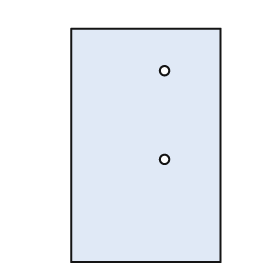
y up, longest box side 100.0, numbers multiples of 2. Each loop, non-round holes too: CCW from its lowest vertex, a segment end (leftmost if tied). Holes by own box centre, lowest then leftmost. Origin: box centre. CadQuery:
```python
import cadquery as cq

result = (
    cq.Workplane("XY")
    .moveTo(-32.0, -50.0)
    .lineTo(32.0, -50.0)
    .lineTo(32.0, 50.0)
    .lineTo(-32.0, 50.0)
    .close()
    .moveTo(8.0, -6.0)
    .circle(2.0)
    .moveTo(8.0, 32.0)
    .circle(2.0)
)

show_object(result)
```